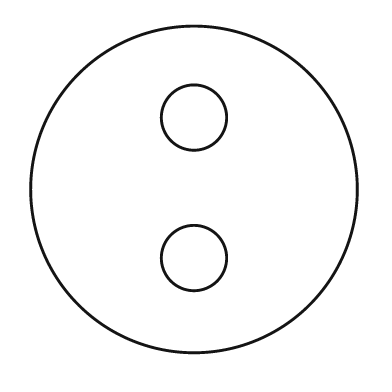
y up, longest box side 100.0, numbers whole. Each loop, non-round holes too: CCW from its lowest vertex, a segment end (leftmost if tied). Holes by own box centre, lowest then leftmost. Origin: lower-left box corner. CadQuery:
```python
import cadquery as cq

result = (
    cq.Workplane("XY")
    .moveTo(50.0, 50.0)
    .circle(50.0)
    .moveTo(50.0, 29.0)
    .circle(10.0)
    .moveTo(50.0, 72.0)
    .circle(10.0)
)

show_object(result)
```